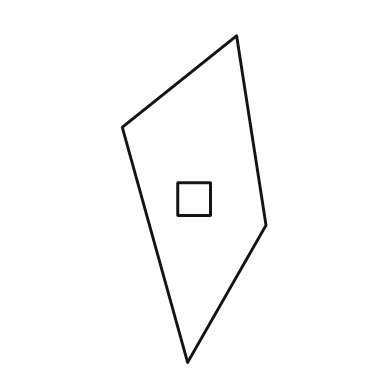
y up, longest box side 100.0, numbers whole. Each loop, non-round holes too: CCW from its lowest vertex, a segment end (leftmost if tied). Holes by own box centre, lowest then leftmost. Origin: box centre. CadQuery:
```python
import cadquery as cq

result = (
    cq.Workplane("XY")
    .moveTo(-2.0, -50.0)
    .lineTo(22.0, -8.0)
    .lineTo(13.0, 50.0)
    .lineTo(-22.0, 22.0)
    .close()
    .moveTo(-5.0, -5.0)
    .lineTo(5.0, -5.0)
    .lineTo(5.0, 5.0)
    .lineTo(-5.0, 5.0)
    .close()
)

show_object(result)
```